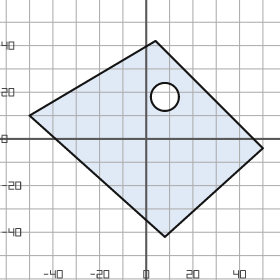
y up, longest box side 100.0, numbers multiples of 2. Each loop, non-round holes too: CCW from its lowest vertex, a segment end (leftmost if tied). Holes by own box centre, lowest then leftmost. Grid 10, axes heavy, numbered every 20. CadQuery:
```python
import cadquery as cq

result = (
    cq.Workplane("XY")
    .moveTo(8.0, -42.0)
    .lineTo(50.0, -4.0)
    .lineTo(4.0, 42.0)
    .lineTo(-50.0, 10.0)
    .close()
    .moveTo(8.0, 18.0)
    .circle(6.0)
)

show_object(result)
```